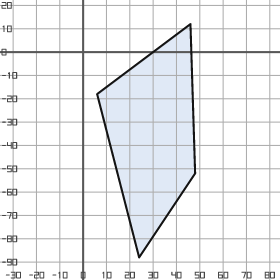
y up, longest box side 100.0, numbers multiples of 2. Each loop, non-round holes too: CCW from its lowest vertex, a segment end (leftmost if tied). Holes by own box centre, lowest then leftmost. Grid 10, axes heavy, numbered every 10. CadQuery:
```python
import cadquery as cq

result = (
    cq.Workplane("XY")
    .moveTo(24.0, -88.0)
    .lineTo(48.0, -52.0)
    .lineTo(46.0, 12.0)
    .lineTo(6.0, -18.0)
    .close()
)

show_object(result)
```